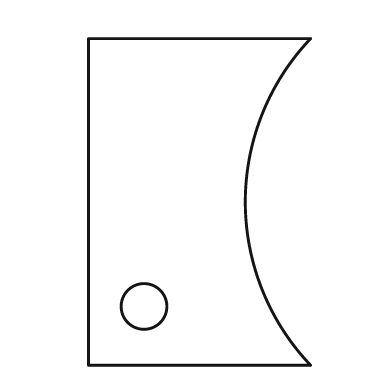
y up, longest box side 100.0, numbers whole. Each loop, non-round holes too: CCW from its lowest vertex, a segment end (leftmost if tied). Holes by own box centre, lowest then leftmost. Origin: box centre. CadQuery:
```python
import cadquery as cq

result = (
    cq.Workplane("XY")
    .moveTo(-34.0, -50.0)
    .lineTo(34.0, -50.0)
    .threePointArc((14.0, 0.0), (34.0, 50.0))
    .lineTo(-34.0, 50.0)
    .close()
    .moveTo(-17.0, -32.0)
    .circle(7.0)
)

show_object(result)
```